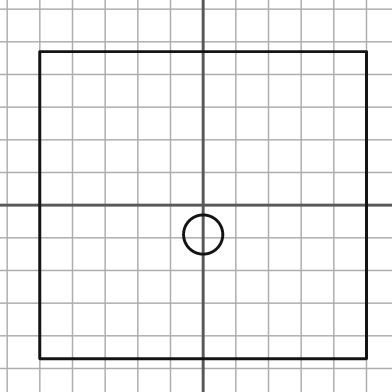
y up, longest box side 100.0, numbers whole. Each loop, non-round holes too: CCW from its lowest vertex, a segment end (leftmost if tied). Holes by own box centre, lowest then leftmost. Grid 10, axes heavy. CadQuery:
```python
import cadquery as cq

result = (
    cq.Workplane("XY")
    .moveTo(-50.0, -47.0)
    .lineTo(50.0, -47.0)
    .lineTo(50.0, 47.0)
    .lineTo(-50.0, 47.0)
    .close()
    .moveTo(0.0, -9.0)
    .circle(6.0)
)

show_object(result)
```